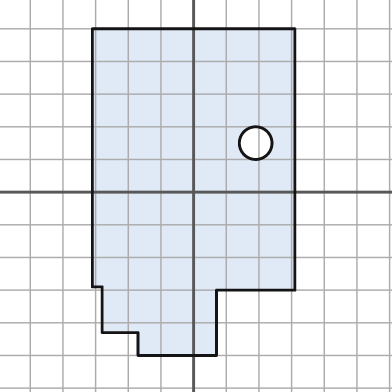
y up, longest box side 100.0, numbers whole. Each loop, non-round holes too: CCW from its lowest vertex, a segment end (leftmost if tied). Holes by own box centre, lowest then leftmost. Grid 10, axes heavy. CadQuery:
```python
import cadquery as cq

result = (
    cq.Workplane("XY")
    .moveTo(-17.0, -50.0)
    .lineTo(7.0, -50.0)
    .lineTo(7.0, -30.0)
    .lineTo(31.0, -30.0)
    .lineTo(31.0, 50.0)
    .lineTo(-31.0, 50.0)
    .lineTo(-31.0, -29.0)
    .lineTo(-28.0, -29.0)
    .lineTo(-28.0, -43.0)
    .lineTo(-17.0, -43.0)
    .close()
    .moveTo(19.0, 15.0)
    .circle(5.0)
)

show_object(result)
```